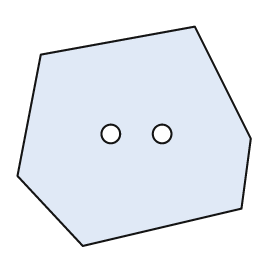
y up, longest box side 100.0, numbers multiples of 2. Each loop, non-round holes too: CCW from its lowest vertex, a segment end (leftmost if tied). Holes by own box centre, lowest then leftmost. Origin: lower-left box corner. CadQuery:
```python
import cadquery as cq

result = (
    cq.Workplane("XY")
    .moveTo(28.0, 0.0)
    .lineTo(96.0, 16.0)
    .lineTo(100.0, 46.0)
    .lineTo(76.0, 94.0)
    .lineTo(10.0, 82.0)
    .lineTo(0.0, 30.0)
    .close()
    .moveTo(40.0, 48.0)
    .circle(4.0)
    .moveTo(62.0, 48.0)
    .circle(4.0)
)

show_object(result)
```